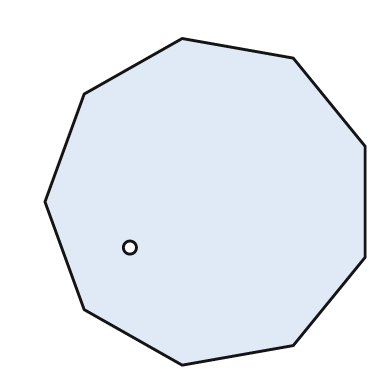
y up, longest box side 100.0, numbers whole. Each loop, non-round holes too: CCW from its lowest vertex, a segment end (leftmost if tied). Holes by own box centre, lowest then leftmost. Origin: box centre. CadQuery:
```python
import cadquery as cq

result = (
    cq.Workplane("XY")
    .moveTo(-7.0, -50.0)
    .lineTo(27.0, -44.0)
    .lineTo(49.0, -17.0)
    .lineTo(49.0, 17.0)
    .lineTo(27.0, 44.0)
    .lineTo(-7.0, 50.0)
    .lineTo(-37.0, 33.0)
    .lineTo(-49.0, 0.0)
    .lineTo(-37.0, -33.0)
    .close()
    .moveTo(-23.0, -14.0)
    .circle(2.0)
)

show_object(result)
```